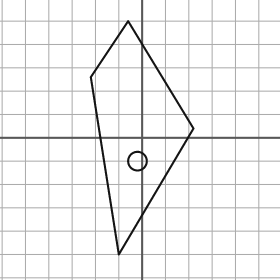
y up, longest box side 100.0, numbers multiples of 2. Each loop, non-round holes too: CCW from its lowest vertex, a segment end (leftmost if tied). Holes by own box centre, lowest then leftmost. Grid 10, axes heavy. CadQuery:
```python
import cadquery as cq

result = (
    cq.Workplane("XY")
    .moveTo(-10.0, -50.0)
    .lineTo(22.0, 4.0)
    .lineTo(-6.0, 50.0)
    .lineTo(-22.0, 26.0)
    .close()
    .moveTo(-2.0, -10.0)
    .circle(4.0)
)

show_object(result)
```